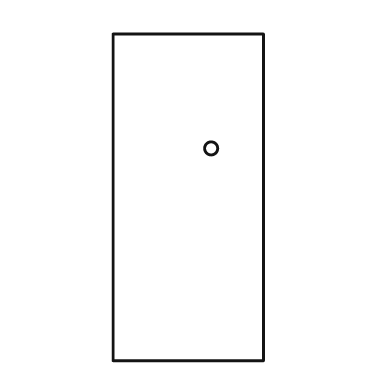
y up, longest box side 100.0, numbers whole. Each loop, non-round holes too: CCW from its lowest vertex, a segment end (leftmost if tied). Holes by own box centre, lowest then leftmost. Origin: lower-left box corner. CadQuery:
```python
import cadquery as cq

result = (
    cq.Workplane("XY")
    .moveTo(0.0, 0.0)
    .lineTo(46.0, 0.0)
    .lineTo(46.0, 100.0)
    .lineTo(0.0, 100.0)
    .close()
    .moveTo(30.0, 65.0)
    .circle(2.0)
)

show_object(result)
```